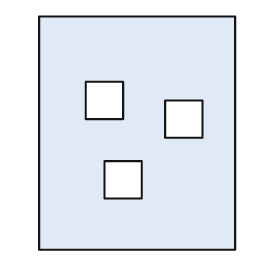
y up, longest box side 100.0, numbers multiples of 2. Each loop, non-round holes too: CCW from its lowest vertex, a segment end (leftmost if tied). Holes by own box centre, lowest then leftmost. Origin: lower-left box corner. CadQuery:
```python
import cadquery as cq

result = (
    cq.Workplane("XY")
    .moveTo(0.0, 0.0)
    .lineTo(84.0, 0.0)
    .lineTo(84.0, 100.0)
    .lineTo(0.0, 100.0)
    .close()
    .moveTo(28.0, 22.0)
    .lineTo(44.0, 22.0)
    .lineTo(44.0, 38.0)
    .lineTo(28.0, 38.0)
    .close()
    .moveTo(54.0, 48.0)
    .lineTo(70.0, 48.0)
    .lineTo(70.0, 64.0)
    .lineTo(54.0, 64.0)
    .close()
    .moveTo(20.0, 56.0)
    .lineTo(36.0, 56.0)
    .lineTo(36.0, 72.0)
    .lineTo(20.0, 72.0)
    .close()
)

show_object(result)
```